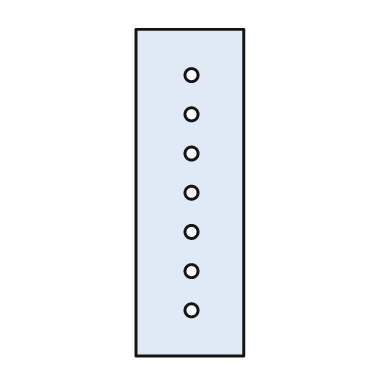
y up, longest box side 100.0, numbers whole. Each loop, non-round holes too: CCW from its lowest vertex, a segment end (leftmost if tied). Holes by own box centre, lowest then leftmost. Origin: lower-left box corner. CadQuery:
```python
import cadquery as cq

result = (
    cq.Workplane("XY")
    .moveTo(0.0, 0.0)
    .lineTo(33.0, 0.0)
    .lineTo(33.0, 100.0)
    .lineTo(0.0, 100.0)
    .close()
    .moveTo(17.0, 14.0)
    .circle(2.0)
    .moveTo(17.0, 26.0)
    .circle(2.0)
    .moveTo(17.0, 38.0)
    .circle(2.0)
    .moveTo(17.0, 50.0)
    .circle(2.0)
    .moveTo(17.0, 62.0)
    .circle(2.0)
    .moveTo(17.0, 74.0)
    .circle(2.0)
    .moveTo(17.0, 86.0)
    .circle(2.0)
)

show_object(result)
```